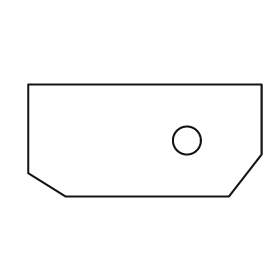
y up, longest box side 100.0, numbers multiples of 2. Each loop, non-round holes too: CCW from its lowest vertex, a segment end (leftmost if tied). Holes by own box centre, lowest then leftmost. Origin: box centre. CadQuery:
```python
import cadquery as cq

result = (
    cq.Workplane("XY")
    .moveTo(-34.0, -24.0)
    .lineTo(36.0, -24.0)
    .lineTo(50.0, -6.0)
    .lineTo(50.0, 24.0)
    .lineTo(-50.0, 24.0)
    .lineTo(-50.0, -14.0)
    .close()
    .moveTo(18.0, 0.0)
    .circle(6.0)
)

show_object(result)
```